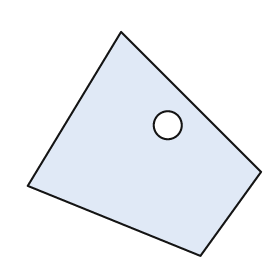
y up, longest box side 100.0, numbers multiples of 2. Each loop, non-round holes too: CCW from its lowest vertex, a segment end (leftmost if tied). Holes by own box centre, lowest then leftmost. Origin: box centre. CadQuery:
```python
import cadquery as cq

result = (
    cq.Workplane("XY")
    .moveTo(24.0, -48.0)
    .lineTo(50.0, -12.0)
    .lineTo(-10.0, 48.0)
    .lineTo(-50.0, -18.0)
    .close()
    .moveTo(10.0, 8.0)
    .circle(6.0)
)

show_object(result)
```